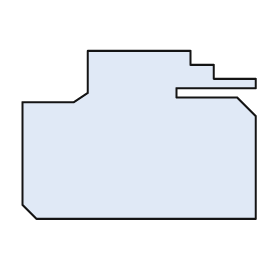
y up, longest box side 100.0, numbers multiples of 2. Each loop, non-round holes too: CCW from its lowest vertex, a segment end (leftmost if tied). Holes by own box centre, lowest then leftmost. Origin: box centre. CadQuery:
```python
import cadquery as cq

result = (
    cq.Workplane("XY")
    .moveTo(-44.0, -36.0)
    .lineTo(50.0, -36.0)
    .lineTo(50.0, 8.0)
    .lineTo(42.0, 16.0)
    .lineTo(16.0, 16.0)
    .lineTo(16.0, 20.0)
    .lineTo(50.0, 20.0)
    .lineTo(50.0, 24.0)
    .lineTo(32.0, 24.0)
    .lineTo(32.0, 30.0)
    .lineTo(22.0, 30.0)
    .lineTo(22.0, 36.0)
    .lineTo(-22.0, 36.0)
    .lineTo(-22.0, 18.0)
    .lineTo(-28.0, 14.0)
    .lineTo(-50.0, 14.0)
    .lineTo(-50.0, -30.0)
    .close()
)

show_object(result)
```